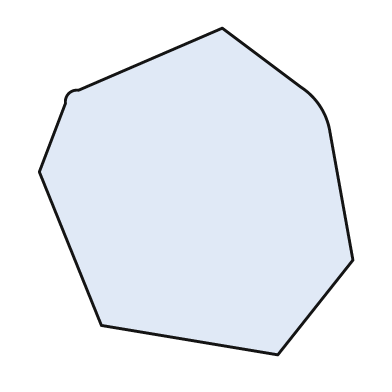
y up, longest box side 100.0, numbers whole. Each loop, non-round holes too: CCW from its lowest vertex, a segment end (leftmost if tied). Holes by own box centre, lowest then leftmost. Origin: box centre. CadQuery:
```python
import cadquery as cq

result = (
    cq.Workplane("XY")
    .moveTo(25.0, -50.0)
    .lineTo(48.0, -21.0)
    .lineTo(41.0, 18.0)
    .threePointArc((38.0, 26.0), (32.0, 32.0))
    .lineTo(8.0, 50.0)
    .lineTo(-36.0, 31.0)
    .threePointArc((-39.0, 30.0), (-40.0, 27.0))
    .lineTo(-48.0, 6.0)
    .lineTo(-29.0, -41.0)
    .close()
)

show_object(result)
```